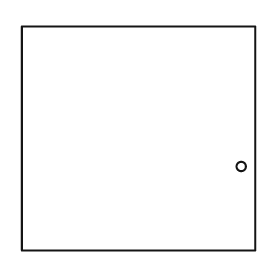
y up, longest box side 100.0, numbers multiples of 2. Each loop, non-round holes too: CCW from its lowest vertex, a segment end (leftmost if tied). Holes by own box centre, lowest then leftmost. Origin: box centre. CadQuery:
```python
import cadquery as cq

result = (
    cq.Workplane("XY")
    .moveTo(-50.0, -48.0)
    .lineTo(50.0, -48.0)
    .lineTo(50.0, 48.0)
    .lineTo(-50.0, 48.0)
    .close()
    .moveTo(44.0, -12.0)
    .circle(2.0)
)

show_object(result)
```